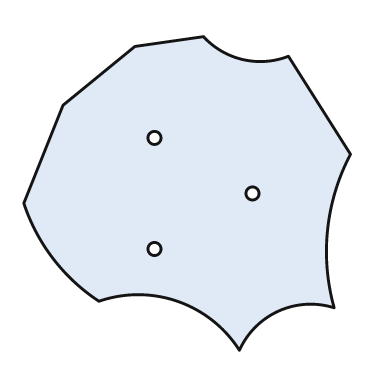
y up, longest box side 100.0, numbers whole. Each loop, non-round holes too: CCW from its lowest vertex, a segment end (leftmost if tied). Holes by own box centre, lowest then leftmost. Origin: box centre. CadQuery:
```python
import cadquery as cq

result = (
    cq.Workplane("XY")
    .moveTo(16.0, -48.0)
    .threePointArc((28.0, -36.0), (45.0, -35.0))
    .threePointArc((43.0, -11.0), (50.0, 12.0))
    .lineTo(31.0, 42.0)
    .threePointArc((17.0, 41.0), (5.0, 48.0))
    .lineTo(-16.0, 45.0)
    .lineTo(-38.0, 27.0)
    .lineTo(-50.0, -3.0)
    .threePointArc((-41.0, -20.0), (-27.0, -33.0))
    .threePointArc((-3.0, -33.0), (16.0, -48.0))
    .close()
    .moveTo(-10.0, -17.0)
    .circle(2.0)
    .moveTo(20.0, 0.0)
    .circle(2.0)
    .moveTo(-10.0, 17.0)
    .circle(2.0)
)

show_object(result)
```